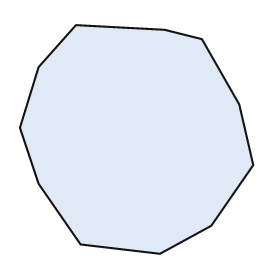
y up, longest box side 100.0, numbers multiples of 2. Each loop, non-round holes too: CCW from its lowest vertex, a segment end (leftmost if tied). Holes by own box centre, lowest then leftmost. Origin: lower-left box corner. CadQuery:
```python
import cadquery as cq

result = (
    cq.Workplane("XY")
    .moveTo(60.0, 0.0)
    .lineTo(82.0, 12.0)
    .lineTo(100.0, 38.0)
    .lineTo(94.0, 64.0)
    .lineTo(78.0, 92.0)
    .lineTo(62.0, 96.0)
    .lineTo(24.0, 98.0)
    .lineTo(8.0, 80.0)
    .lineTo(0.0, 54.0)
    .lineTo(8.0, 30.0)
    .lineTo(26.0, 4.0)
    .close()
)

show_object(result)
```